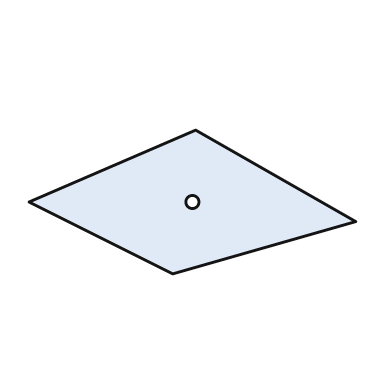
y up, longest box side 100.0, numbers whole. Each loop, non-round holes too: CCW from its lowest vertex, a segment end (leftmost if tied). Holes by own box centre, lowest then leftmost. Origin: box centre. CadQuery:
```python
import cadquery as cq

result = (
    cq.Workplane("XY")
    .moveTo(-6.0, -22.0)
    .lineTo(50.0, -6.0)
    .lineTo(1.0, 22.0)
    .lineTo(-50.0, 0.0)
    .close()
    .moveTo(0.0, 0.0)
    .circle(2.0)
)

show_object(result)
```